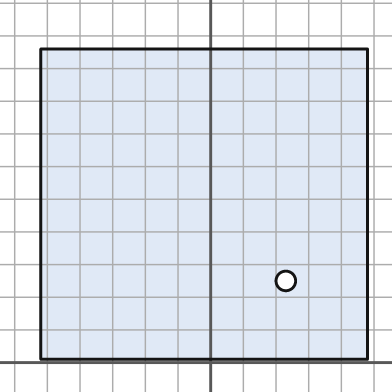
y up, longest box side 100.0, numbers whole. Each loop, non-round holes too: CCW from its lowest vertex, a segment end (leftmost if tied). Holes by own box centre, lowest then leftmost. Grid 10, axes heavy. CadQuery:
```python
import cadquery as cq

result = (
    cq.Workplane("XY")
    .moveTo(-52.0, 1.0)
    .lineTo(48.0, 1.0)
    .lineTo(48.0, 96.0)
    .lineTo(-52.0, 96.0)
    .close()
    .moveTo(23.0, 25.0)
    .circle(3.0)
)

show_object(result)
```